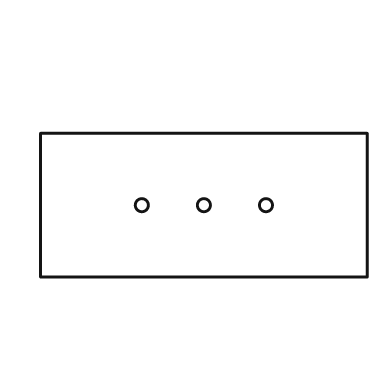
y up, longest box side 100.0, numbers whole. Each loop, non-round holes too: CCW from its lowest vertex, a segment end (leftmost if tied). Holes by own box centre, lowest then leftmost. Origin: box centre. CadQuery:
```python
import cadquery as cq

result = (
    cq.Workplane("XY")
    .moveTo(-50.0, -22.0)
    .lineTo(50.0, -22.0)
    .lineTo(50.0, 22.0)
    .lineTo(-50.0, 22.0)
    .close()
    .moveTo(-19.0, 0.0)
    .circle(2.0)
    .moveTo(0.0, 0.0)
    .circle(2.0)
    .moveTo(19.0, 0.0)
    .circle(2.0)
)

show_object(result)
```